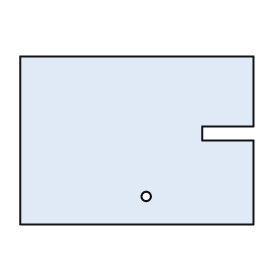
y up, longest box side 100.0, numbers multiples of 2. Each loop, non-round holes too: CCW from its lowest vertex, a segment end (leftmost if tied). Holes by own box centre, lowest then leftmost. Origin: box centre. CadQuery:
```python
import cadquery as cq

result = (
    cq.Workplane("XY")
    .moveTo(-50.0, -36.0)
    .lineTo(50.0, -36.0)
    .lineTo(50.0, 0.0)
    .lineTo(28.0, 0.0)
    .lineTo(28.0, 6.0)
    .lineTo(50.0, 6.0)
    .lineTo(50.0, 36.0)
    .lineTo(-50.0, 36.0)
    .close()
    .moveTo(4.0, -24.0)
    .circle(2.0)
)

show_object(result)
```